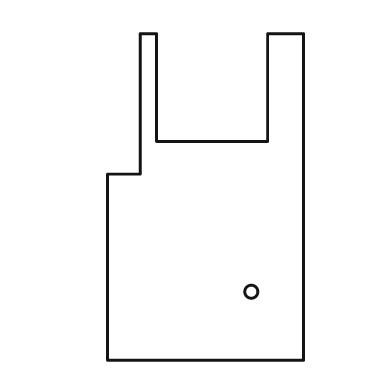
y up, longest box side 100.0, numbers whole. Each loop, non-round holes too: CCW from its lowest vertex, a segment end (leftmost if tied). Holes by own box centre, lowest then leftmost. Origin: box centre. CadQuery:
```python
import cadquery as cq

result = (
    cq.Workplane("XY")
    .moveTo(-30.0, -50.0)
    .lineTo(30.0, -50.0)
    .lineTo(30.0, 50.0)
    .lineTo(19.0, 50.0)
    .lineTo(19.0, 17.0)
    .lineTo(-15.0, 17.0)
    .lineTo(-15.0, 50.0)
    .lineTo(-20.0, 50.0)
    .lineTo(-20.0, 7.0)
    .lineTo(-30.0, 7.0)
    .close()
    .moveTo(14.0, -29.0)
    .circle(2.0)
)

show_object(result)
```